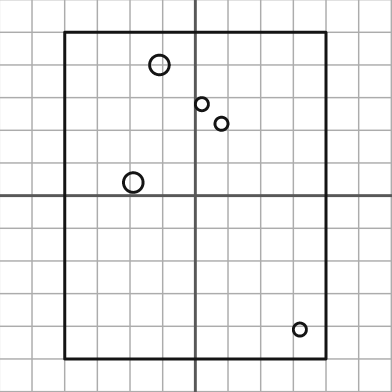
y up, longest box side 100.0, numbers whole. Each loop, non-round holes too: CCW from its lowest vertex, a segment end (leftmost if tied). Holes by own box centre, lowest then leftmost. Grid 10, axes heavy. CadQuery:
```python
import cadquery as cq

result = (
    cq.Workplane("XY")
    .moveTo(-40.0, -50.0)
    .lineTo(40.0, -50.0)
    .lineTo(40.0, 50.0)
    .lineTo(-40.0, 50.0)
    .close()
    .moveTo(32.0, -41.0)
    .circle(2.0)
    .moveTo(-19.0, 4.0)
    .circle(3.0)
    .moveTo(8.0, 22.0)
    .circle(2.0)
    .moveTo(2.0, 28.0)
    .circle(2.0)
    .moveTo(-11.0, 40.0)
    .circle(3.0)
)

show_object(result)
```